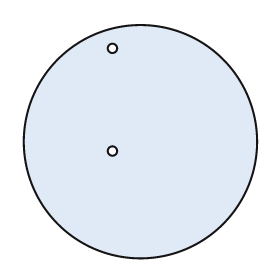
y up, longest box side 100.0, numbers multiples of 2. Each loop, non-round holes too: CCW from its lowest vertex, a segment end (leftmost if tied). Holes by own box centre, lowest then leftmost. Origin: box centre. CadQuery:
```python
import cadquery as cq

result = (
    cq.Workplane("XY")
    .moveTo(0.0, 0.0)
    .circle(50.0)
    .moveTo(-12.0, -4.0)
    .circle(2.0)
    .moveTo(-12.0, 40.0)
    .circle(2.0)
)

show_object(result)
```